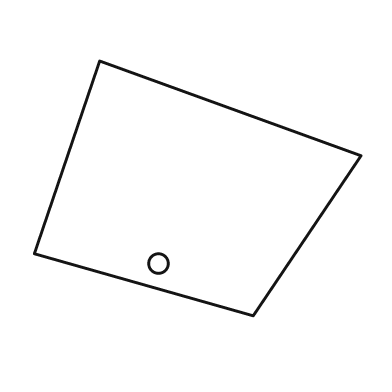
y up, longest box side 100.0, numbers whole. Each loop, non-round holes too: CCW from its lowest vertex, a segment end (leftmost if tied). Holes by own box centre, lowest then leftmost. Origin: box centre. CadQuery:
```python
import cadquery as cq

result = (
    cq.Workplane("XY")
    .moveTo(17.0, -39.0)
    .lineTo(50.0, 10.0)
    .lineTo(-30.0, 39.0)
    .lineTo(-50.0, -20.0)
    .close()
    .moveTo(-12.0, -23.0)
    .circle(3.0)
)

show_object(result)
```